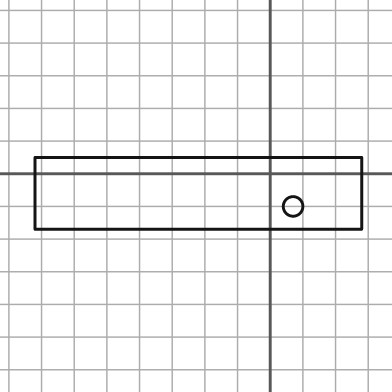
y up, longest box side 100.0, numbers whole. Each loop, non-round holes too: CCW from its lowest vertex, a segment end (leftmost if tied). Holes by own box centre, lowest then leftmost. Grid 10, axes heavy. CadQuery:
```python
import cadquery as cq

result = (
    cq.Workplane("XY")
    .moveTo(-72.0, -17.0)
    .lineTo(28.0, -17.0)
    .lineTo(28.0, 5.0)
    .lineTo(-72.0, 5.0)
    .close()
    .moveTo(7.0, -10.0)
    .circle(3.0)
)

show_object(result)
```